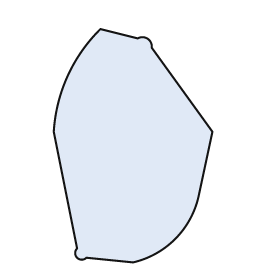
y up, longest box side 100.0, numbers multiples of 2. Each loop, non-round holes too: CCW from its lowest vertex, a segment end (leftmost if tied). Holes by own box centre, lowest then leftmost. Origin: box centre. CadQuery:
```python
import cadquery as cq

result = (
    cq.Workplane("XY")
    .moveTo(0.0, -50.0)
    .threePointArc((18.0, -40.0), (28.0, -22.0))
    .lineTo(34.0, 6.0)
    .lineTo(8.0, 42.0)
    .threePointArc((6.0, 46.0), (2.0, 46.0))
    .lineTo(-14.0, 50.0)
    .threePointArc((-28.0, 30.0), (-34.0, 6.0))
    .lineTo(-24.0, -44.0)
    .threePointArc((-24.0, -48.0), (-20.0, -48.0))
    .close()
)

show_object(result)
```